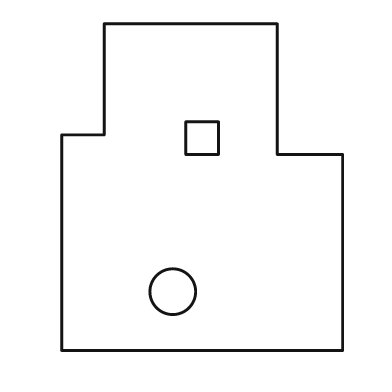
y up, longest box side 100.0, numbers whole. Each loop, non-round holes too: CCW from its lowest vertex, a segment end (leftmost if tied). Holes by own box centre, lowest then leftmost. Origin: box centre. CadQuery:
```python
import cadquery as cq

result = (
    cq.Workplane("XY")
    .moveTo(-43.0, -50.0)
    .lineTo(43.0, -50.0)
    .lineTo(43.0, 10.0)
    .lineTo(23.0, 10.0)
    .lineTo(23.0, 50.0)
    .lineTo(-30.0, 50.0)
    .lineTo(-30.0, 16.0)
    .lineTo(-43.0, 16.0)
    .close()
    .moveTo(-9.0, -32.0)
    .circle(7.0)
    .moveTo(-5.0, 10.0)
    .lineTo(5.0, 10.0)
    .lineTo(5.0, 20.0)
    .lineTo(-5.0, 20.0)
    .close()
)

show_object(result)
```